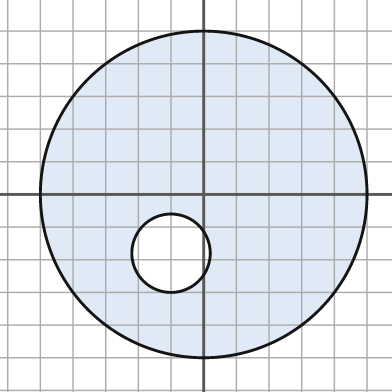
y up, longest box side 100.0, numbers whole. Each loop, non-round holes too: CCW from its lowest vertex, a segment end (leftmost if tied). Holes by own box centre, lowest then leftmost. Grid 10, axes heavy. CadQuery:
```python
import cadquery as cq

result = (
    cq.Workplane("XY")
    .moveTo(0.0, 0.0)
    .circle(50.0)
    .moveTo(-10.0, -18.0)
    .circle(12.0)
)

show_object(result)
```